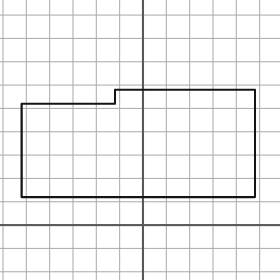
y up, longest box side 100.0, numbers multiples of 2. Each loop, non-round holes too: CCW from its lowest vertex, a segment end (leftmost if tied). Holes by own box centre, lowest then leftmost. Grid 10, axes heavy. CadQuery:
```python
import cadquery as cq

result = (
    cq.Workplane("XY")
    .moveTo(-52.0, 12.0)
    .lineTo(48.0, 12.0)
    .lineTo(48.0, 58.0)
    .lineTo(-12.0, 58.0)
    .lineTo(-12.0, 52.0)
    .lineTo(-52.0, 52.0)
    .close()
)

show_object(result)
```